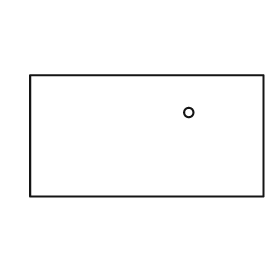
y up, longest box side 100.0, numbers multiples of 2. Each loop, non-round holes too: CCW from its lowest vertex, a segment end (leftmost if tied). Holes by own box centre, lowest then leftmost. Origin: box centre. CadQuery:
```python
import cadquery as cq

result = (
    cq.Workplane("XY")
    .moveTo(-50.0, -26.0)
    .lineTo(50.0, -26.0)
    .lineTo(50.0, 26.0)
    .lineTo(-50.0, 26.0)
    .close()
    .moveTo(18.0, 10.0)
    .circle(2.0)
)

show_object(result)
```